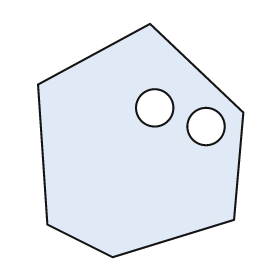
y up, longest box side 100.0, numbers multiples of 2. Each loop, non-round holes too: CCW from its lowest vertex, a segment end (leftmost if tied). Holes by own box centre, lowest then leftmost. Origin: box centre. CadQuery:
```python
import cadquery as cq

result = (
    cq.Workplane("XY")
    .moveTo(-12.0, -50.0)
    .lineTo(40.0, -34.0)
    .lineTo(44.0, 12.0)
    .lineTo(4.0, 50.0)
    .lineTo(-44.0, 24.0)
    .lineTo(-40.0, -36.0)
    .close()
    .moveTo(28.0, 6.0)
    .circle(8.0)
    .moveTo(6.0, 14.0)
    .circle(8.0)
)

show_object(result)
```